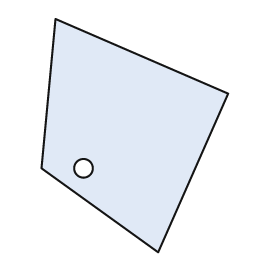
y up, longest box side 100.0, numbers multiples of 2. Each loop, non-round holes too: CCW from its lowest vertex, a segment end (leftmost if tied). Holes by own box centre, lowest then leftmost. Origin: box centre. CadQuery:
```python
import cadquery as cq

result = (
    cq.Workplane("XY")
    .moveTo(10.0, -50.0)
    .lineTo(40.0, 18.0)
    .lineTo(-34.0, 50.0)
    .lineTo(-40.0, -14.0)
    .close()
    .moveTo(-22.0, -14.0)
    .circle(4.0)
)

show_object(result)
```